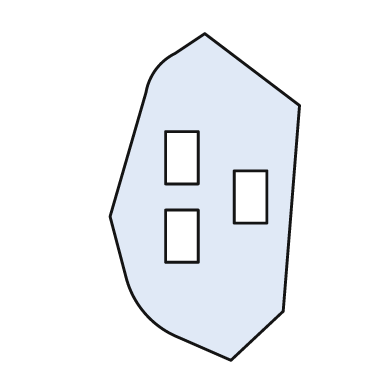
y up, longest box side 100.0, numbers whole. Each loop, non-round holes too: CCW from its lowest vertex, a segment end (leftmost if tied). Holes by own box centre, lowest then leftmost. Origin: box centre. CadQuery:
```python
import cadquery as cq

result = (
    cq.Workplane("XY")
    .moveTo(8.0, -50.0)
    .lineTo(24.0, -35.0)
    .lineTo(29.0, 28.0)
    .lineTo(0.0, 50.0)
    .lineTo(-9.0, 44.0)
    .threePointArc((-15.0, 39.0), (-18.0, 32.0))
    .lineTo(-29.0, -6.0)
    .lineTo(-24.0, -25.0)
    .threePointArc((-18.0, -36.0), (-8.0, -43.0))
    .close()
    .moveTo(-12.0, -20.0)
    .lineTo(-2.0, -20.0)
    .lineTo(-2.0, -4.0)
    .lineTo(-12.0, -4.0)
    .close()
    .moveTo(9.0, -8.0)
    .lineTo(19.0, -8.0)
    .lineTo(19.0, 8.0)
    .lineTo(9.0, 8.0)
    .close()
    .moveTo(-12.0, 4.0)
    .lineTo(-2.0, 4.0)
    .lineTo(-2.0, 20.0)
    .lineTo(-12.0, 20.0)
    .close()
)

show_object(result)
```